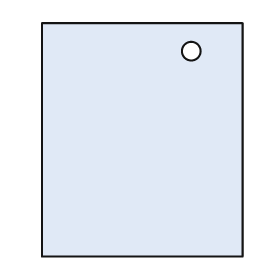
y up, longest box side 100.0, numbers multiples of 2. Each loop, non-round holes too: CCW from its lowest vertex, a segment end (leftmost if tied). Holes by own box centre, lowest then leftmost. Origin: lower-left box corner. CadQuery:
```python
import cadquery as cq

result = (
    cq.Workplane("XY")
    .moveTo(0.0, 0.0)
    .lineTo(86.0, 0.0)
    .lineTo(86.0, 100.0)
    .lineTo(0.0, 100.0)
    .close()
    .moveTo(64.0, 88.0)
    .circle(4.0)
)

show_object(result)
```